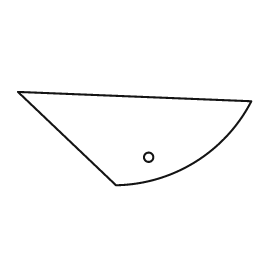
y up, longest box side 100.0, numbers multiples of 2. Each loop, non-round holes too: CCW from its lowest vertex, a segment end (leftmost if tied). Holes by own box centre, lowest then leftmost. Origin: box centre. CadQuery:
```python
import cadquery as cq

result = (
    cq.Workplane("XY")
    .moveTo(-8.0, -20.0)
    .threePointArc((26.0, -10.0), (50.0, 16.0))
    .lineTo(-50.0, 20.0)
    .close()
    .moveTo(6.0, -8.0)
    .circle(2.0)
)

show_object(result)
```